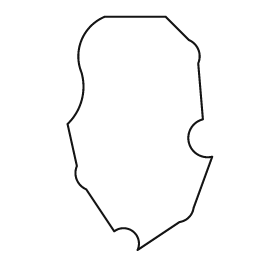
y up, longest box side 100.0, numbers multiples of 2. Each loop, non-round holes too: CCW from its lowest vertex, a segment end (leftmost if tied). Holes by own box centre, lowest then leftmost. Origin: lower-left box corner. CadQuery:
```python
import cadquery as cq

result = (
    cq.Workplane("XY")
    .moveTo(30.0, 0.0)
    .lineTo(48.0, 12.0)
    .threePointArc((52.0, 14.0), (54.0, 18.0))
    .lineTo(62.0, 40.0)
    .threePointArc((52.0, 46.0), (58.0, 56.0))
    .lineTo(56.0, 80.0)
    .threePointArc((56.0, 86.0), (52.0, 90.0))
    .lineTo(42.0, 100.0)
    .lineTo(16.0, 100.0)
    .threePointArc((6.0, 90.0), (6.0, 76.0))
    .threePointArc((6.0, 64.0), (0.0, 54.0))
    .lineTo(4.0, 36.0)
    .threePointArc((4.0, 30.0), (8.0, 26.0))
    .lineTo(20.0, 8.0)
    .threePointArc((28.0, 8.0), (30.0, 0.0))
    .close()
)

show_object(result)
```